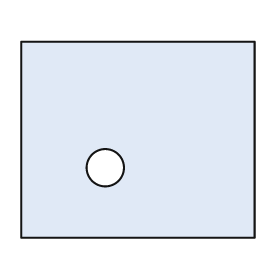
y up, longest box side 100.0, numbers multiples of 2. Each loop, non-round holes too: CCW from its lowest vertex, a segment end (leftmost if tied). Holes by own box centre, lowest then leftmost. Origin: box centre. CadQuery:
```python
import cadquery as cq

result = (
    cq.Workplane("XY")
    .moveTo(-50.0, -42.0)
    .lineTo(50.0, -42.0)
    .lineTo(50.0, 42.0)
    .lineTo(-50.0, 42.0)
    .close()
    .moveTo(-14.0, -12.0)
    .circle(8.0)
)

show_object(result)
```